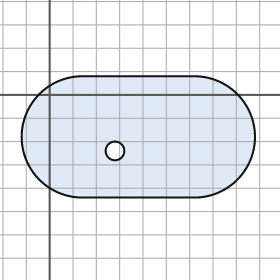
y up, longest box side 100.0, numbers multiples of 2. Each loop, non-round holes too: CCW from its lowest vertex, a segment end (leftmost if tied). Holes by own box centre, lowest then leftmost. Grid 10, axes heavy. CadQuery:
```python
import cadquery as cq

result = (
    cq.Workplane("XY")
    .moveTo(14.0, -44.0)
    .lineTo(62.0, -44.0)
    .threePointArc((88.0, -18.0), (62.0, 8.0))
    .lineTo(14.0, 8.0)
    .threePointArc((-12.0, -18.0), (14.0, -44.0))
    .close()
    .moveTo(28.0, -24.0)
    .circle(4.0)
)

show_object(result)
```